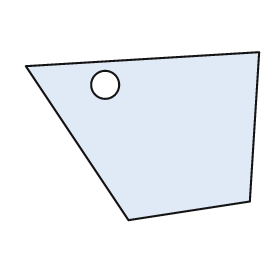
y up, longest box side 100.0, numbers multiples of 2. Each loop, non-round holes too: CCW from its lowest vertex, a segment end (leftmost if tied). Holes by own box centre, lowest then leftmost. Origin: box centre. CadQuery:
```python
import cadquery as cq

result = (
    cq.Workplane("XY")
    .moveTo(-6.0, -36.0)
    .lineTo(46.0, -28.0)
    .lineTo(50.0, 36.0)
    .lineTo(-50.0, 30.0)
    .close()
    .moveTo(-16.0, 22.0)
    .circle(6.0)
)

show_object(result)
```